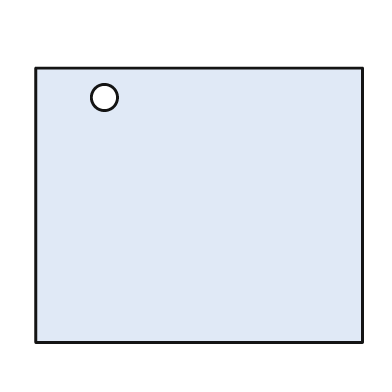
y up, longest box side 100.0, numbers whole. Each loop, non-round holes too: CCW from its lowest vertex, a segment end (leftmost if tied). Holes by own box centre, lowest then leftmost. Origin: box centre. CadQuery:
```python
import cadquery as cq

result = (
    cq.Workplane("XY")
    .moveTo(-50.0, -42.0)
    .lineTo(50.0, -42.0)
    .lineTo(50.0, 42.0)
    .lineTo(-50.0, 42.0)
    .close()
    .moveTo(-29.0, 33.0)
    .circle(4.0)
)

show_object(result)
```